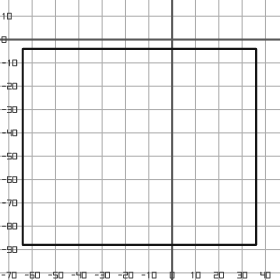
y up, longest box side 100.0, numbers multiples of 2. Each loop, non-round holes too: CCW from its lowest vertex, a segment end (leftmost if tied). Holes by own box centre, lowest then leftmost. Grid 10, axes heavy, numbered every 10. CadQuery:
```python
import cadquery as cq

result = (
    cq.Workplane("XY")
    .moveTo(-64.0, -88.0)
    .lineTo(36.0, -88.0)
    .lineTo(36.0, -4.0)
    .lineTo(-64.0, -4.0)
    .close()
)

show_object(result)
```